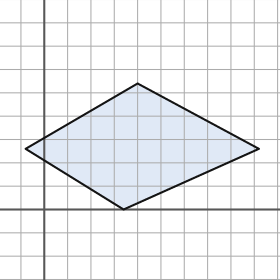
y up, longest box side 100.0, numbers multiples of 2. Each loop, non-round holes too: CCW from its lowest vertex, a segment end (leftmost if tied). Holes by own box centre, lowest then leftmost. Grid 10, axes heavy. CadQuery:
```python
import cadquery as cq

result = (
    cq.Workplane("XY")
    .moveTo(34.0, 0.0)
    .lineTo(92.0, 26.0)
    .lineTo(40.0, 54.0)
    .lineTo(-8.0, 26.0)
    .close()
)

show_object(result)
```